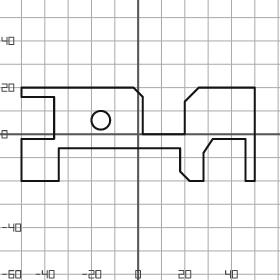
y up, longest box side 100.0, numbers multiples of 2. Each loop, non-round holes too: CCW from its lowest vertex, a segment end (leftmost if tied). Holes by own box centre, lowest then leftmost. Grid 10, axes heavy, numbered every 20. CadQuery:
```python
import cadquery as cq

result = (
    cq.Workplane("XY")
    .moveTo(-50.0, -20.0)
    .lineTo(-34.0, -20.0)
    .lineTo(-34.0, -6.0)
    .lineTo(18.0, -6.0)
    .lineTo(18.0, -16.0)
    .lineTo(22.0, -20.0)
    .lineTo(28.0, -20.0)
    .lineTo(28.0, -8.0)
    .lineTo(32.0, -2.0)
    .lineTo(46.0, -2.0)
    .lineTo(46.0, -20.0)
    .lineTo(50.0, -20.0)
    .lineTo(50.0, 20.0)
    .lineTo(26.0, 20.0)
    .lineTo(20.0, 14.0)
    .lineTo(20.0, 0.0)
    .lineTo(2.0, 0.0)
    .lineTo(2.0, 16.0)
    .lineTo(-2.0, 20.0)
    .lineTo(-50.0, 20.0)
    .lineTo(-50.0, 16.0)
    .lineTo(-36.0, 16.0)
    .lineTo(-36.0, -2.0)
    .lineTo(-50.0, -2.0)
    .close()
    .moveTo(-16.0, 6.0)
    .circle(4.0)
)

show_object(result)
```